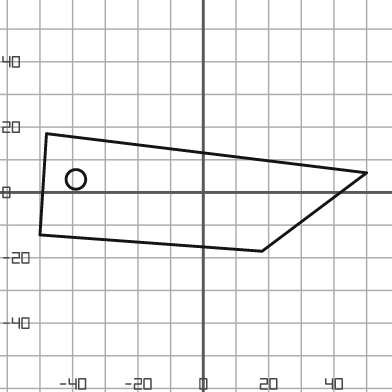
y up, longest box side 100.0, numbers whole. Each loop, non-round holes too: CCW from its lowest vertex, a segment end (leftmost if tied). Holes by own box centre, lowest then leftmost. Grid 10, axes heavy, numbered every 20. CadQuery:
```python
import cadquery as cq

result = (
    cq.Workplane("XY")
    .moveTo(18.0, -18.0)
    .lineTo(50.0, 6.0)
    .lineTo(-48.0, 18.0)
    .lineTo(-50.0, -13.0)
    .close()
    .moveTo(-39.0, 4.0)
    .circle(3.0)
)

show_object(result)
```